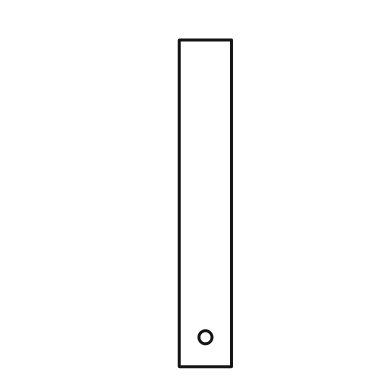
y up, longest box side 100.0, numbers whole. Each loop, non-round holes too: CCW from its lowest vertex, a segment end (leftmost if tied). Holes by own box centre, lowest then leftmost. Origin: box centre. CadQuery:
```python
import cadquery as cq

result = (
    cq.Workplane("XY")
    .moveTo(-8.0, -50.0)
    .lineTo(8.0, -50.0)
    .lineTo(8.0, 50.0)
    .lineTo(-8.0, 50.0)
    .close()
    .moveTo(0.0, -41.0)
    .circle(2.0)
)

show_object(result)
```